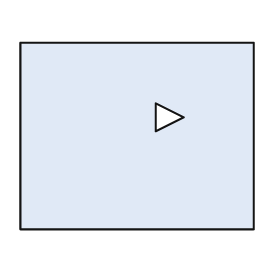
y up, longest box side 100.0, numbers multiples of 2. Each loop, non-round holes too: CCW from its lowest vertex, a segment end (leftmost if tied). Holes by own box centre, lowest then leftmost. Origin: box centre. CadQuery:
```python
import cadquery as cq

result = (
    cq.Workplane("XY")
    .moveTo(-50.0, -40.0)
    .lineTo(50.0, -40.0)
    .lineTo(50.0, 40.0)
    .lineTo(-50.0, 40.0)
    .close()
    .moveTo(8.0, 2.0)
    .lineTo(20.0, 8.0)
    .lineTo(8.0, 14.0)
    .close()
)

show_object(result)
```